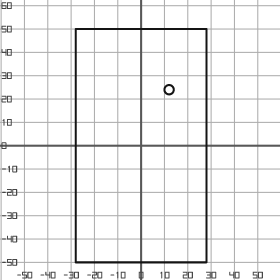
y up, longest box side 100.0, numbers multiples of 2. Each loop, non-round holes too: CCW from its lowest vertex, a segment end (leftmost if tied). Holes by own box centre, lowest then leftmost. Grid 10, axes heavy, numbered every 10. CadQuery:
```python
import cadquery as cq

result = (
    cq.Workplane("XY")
    .moveTo(-28.0, -50.0)
    .lineTo(28.0, -50.0)
    .lineTo(28.0, 50.0)
    .lineTo(-28.0, 50.0)
    .close()
    .moveTo(12.0, 24.0)
    .circle(2.0)
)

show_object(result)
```